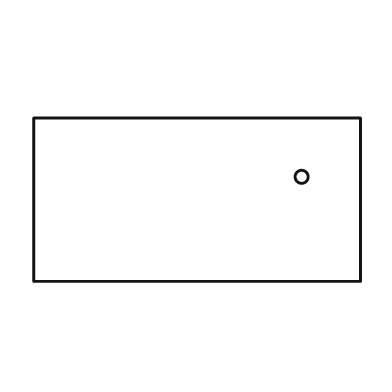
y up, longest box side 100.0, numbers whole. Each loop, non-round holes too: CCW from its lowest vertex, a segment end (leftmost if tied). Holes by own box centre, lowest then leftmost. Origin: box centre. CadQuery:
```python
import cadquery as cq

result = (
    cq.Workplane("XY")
    .moveTo(-50.0, -25.0)
    .lineTo(50.0, -25.0)
    .lineTo(50.0, 25.0)
    .lineTo(-50.0, 25.0)
    .close()
    .moveTo(32.0, 7.0)
    .circle(2.0)
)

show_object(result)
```